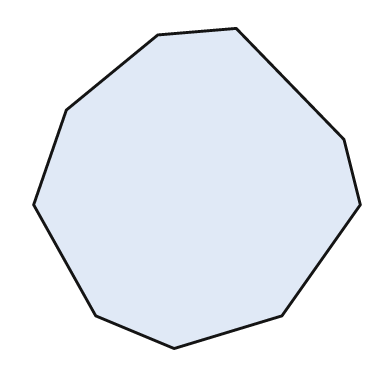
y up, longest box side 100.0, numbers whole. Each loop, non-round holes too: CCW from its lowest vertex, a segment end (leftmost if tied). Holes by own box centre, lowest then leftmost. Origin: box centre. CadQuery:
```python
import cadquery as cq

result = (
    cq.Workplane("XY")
    .moveTo(-7.0, -49.0)
    .lineTo(26.0, -39.0)
    .lineTo(50.0, -5.0)
    .lineTo(45.0, 15.0)
    .lineTo(12.0, 49.0)
    .lineTo(-12.0, 47.0)
    .lineTo(-40.0, 24.0)
    .lineTo(-50.0, -5.0)
    .lineTo(-31.0, -39.0)
    .close()
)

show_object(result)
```